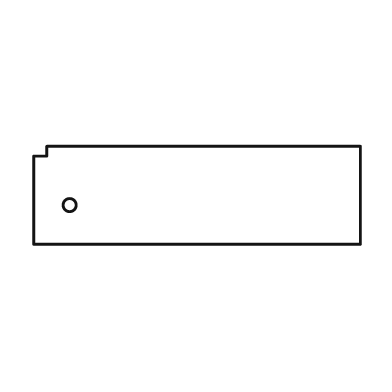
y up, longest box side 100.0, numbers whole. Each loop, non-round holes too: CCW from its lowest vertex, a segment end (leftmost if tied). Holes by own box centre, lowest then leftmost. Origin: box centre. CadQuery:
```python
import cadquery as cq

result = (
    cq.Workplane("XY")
    .moveTo(-50.0, -15.0)
    .lineTo(50.0, -15.0)
    .lineTo(50.0, 15.0)
    .lineTo(-46.0, 15.0)
    .lineTo(-46.0, 12.0)
    .lineTo(-50.0, 12.0)
    .close()
    .moveTo(-39.0, -3.0)
    .circle(2.0)
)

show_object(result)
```